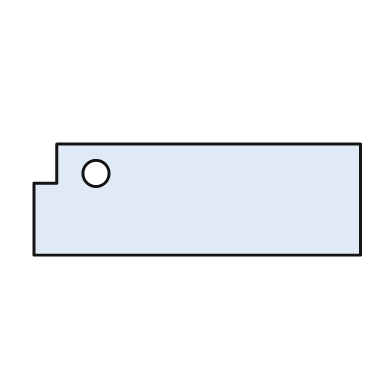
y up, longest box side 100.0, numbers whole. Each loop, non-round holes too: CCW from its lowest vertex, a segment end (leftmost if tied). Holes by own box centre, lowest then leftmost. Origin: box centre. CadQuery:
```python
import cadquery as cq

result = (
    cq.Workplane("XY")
    .moveTo(-50.0, -17.0)
    .lineTo(50.0, -17.0)
    .lineTo(50.0, 17.0)
    .lineTo(-43.0, 17.0)
    .lineTo(-43.0, 5.0)
    .lineTo(-50.0, 5.0)
    .close()
    .moveTo(-31.0, 8.0)
    .circle(4.0)
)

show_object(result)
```